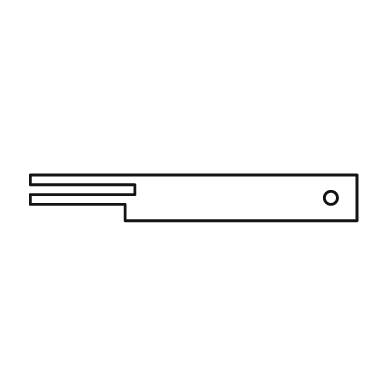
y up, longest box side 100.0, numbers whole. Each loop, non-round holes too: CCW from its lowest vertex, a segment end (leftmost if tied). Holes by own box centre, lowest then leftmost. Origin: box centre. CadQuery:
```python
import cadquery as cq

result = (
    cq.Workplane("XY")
    .moveTo(-21.0, -7.0)
    .lineTo(50.0, -7.0)
    .lineTo(50.0, 7.0)
    .lineTo(-50.0, 7.0)
    .lineTo(-50.0, 4.0)
    .lineTo(-18.0, 4.0)
    .lineTo(-18.0, 1.0)
    .lineTo(-50.0, 1.0)
    .lineTo(-50.0, -2.0)
    .lineTo(-21.0, -2.0)
    .close()
    .moveTo(42.0, 0.0)
    .circle(2.0)
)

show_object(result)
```